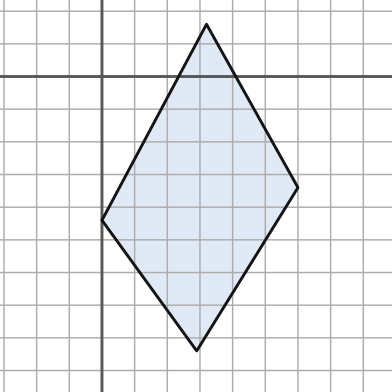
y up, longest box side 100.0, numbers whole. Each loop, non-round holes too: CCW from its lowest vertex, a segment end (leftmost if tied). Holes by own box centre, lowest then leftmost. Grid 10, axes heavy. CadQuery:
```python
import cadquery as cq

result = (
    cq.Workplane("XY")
    .moveTo(29.0, -84.0)
    .lineTo(60.0, -34.0)
    .lineTo(32.0, 16.0)
    .lineTo(0.0, -44.0)
    .close()
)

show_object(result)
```